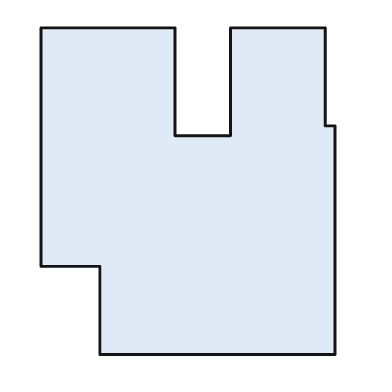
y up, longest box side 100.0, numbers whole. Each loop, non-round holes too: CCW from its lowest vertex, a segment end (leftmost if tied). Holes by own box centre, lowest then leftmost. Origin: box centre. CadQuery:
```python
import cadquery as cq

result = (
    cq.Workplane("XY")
    .moveTo(-27.0, -50.0)
    .lineTo(45.0, -50.0)
    .lineTo(45.0, 20.0)
    .lineTo(42.0, 20.0)
    .lineTo(42.0, 50.0)
    .lineTo(13.0, 50.0)
    .lineTo(13.0, 17.0)
    .lineTo(-4.0, 17.0)
    .lineTo(-4.0, 50.0)
    .lineTo(-45.0, 50.0)
    .lineTo(-45.0, -23.0)
    .lineTo(-27.0, -23.0)
    .close()
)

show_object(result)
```